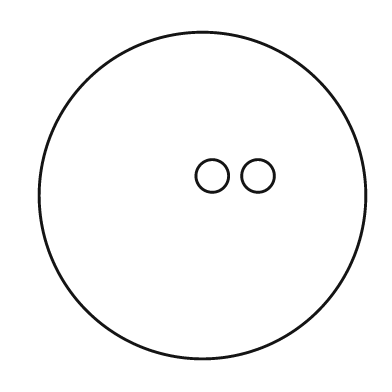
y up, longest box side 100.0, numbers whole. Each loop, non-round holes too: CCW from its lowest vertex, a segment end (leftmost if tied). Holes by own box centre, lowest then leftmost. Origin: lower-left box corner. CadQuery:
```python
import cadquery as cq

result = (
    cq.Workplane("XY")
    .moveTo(50.0, 50.0)
    .circle(50.0)
    .moveTo(53.0, 56.0)
    .circle(5.0)
    .moveTo(67.0, 56.0)
    .circle(5.0)
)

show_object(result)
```